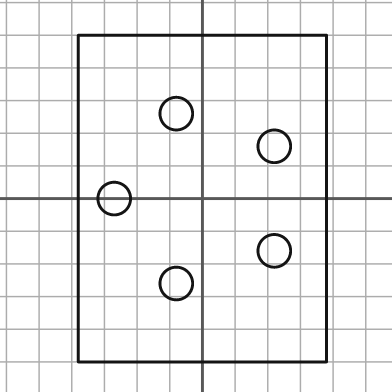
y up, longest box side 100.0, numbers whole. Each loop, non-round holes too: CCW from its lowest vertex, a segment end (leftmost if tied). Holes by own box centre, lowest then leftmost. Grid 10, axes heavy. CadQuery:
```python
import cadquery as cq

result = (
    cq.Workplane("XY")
    .moveTo(-38.0, -50.0)
    .lineTo(38.0, -50.0)
    .lineTo(38.0, 50.0)
    .lineTo(-38.0, 50.0)
    .close()
    .moveTo(-8.0, -26.0)
    .circle(5.0)
    .moveTo(22.0, -16.0)
    .circle(5.0)
    .moveTo(-27.0, 0.0)
    .circle(5.0)
    .moveTo(22.0, 16.0)
    .circle(5.0)
    .moveTo(-8.0, 26.0)
    .circle(5.0)
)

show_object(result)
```